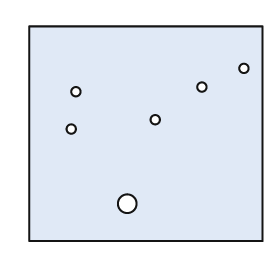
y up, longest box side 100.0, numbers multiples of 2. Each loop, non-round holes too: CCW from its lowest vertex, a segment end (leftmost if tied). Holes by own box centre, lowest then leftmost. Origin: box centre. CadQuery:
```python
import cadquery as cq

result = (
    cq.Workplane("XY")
    .moveTo(-50.0, -46.0)
    .lineTo(50.0, -46.0)
    .lineTo(50.0, 46.0)
    .lineTo(-50.0, 46.0)
    .close()
    .moveTo(-8.0, -30.0)
    .circle(4.0)
    .moveTo(-32.0, 2.0)
    .circle(2.0)
    .moveTo(4.0, 6.0)
    .circle(2.0)
    .moveTo(-30.0, 18.0)
    .circle(2.0)
    .moveTo(24.0, 20.0)
    .circle(2.0)
    .moveTo(42.0, 28.0)
    .circle(2.0)
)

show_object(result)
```